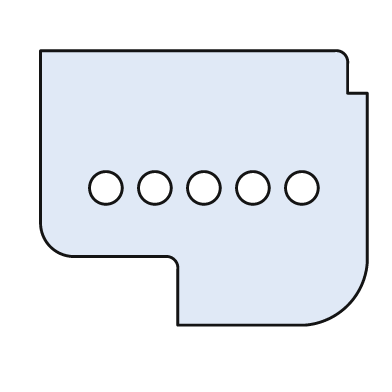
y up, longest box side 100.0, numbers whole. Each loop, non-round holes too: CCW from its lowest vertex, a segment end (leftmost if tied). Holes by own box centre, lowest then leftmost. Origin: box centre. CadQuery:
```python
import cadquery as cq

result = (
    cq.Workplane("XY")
    .moveTo(-8.0, -42.0)
    .lineTo(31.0, -42.0)
    .threePointArc((44.0, -36.0), (50.0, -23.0))
    .lineTo(50.0, 29.0)
    .lineTo(44.0, 29.0)
    .lineTo(44.0, 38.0)
    .threePointArc((43.0, 41.0), (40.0, 42.0))
    .lineTo(-50.0, 42.0)
    .lineTo(-50.0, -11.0)
    .threePointArc((-47.0, -18.0), (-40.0, -21.0))
    .lineTo(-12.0, -21.0)
    .threePointArc((-9.0, -22.0), (-8.0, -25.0))
    .close()
    .moveTo(-30.0, 0.0)
    .circle(5.0)
    .moveTo(-15.0, 0.0)
    .circle(5.0)
    .moveTo(0.0, 0.0)
    .circle(5.0)
    .moveTo(15.0, 0.0)
    .circle(5.0)
    .moveTo(30.0, 0.0)
    .circle(5.0)
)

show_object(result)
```